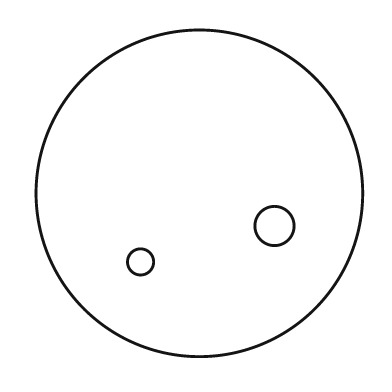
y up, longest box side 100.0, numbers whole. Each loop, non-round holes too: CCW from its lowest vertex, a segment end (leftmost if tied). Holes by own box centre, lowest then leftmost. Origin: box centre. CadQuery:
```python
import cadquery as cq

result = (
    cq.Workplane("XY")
    .moveTo(0.0, 0.0)
    .circle(50.0)
    .moveTo(-18.0, -21.0)
    .circle(4.0)
    .moveTo(23.0, -10.0)
    .circle(6.0)
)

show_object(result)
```